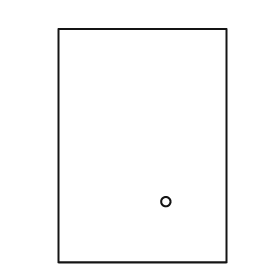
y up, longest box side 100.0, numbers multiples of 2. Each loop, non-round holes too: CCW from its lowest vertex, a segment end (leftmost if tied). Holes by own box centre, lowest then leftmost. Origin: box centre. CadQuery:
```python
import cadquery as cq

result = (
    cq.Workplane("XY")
    .moveTo(-36.0, -50.0)
    .lineTo(36.0, -50.0)
    .lineTo(36.0, 50.0)
    .lineTo(-36.0, 50.0)
    .close()
    .moveTo(10.0, -24.0)
    .circle(2.0)
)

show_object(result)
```